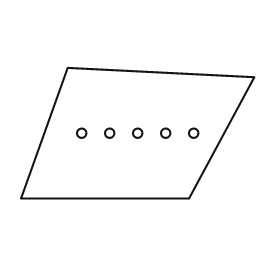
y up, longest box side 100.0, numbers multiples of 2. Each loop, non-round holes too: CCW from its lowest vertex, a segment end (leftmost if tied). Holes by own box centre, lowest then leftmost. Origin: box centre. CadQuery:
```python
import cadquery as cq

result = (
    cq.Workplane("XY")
    .moveTo(-50.0, -28.0)
    .lineTo(22.0, -28.0)
    .lineTo(50.0, 24.0)
    .lineTo(-30.0, 28.0)
    .close()
    .moveTo(-24.0, 0.0)
    .circle(2.0)
    .moveTo(-12.0, 0.0)
    .circle(2.0)
    .moveTo(0.0, 0.0)
    .circle(2.0)
    .moveTo(12.0, 0.0)
    .circle(2.0)
    .moveTo(24.0, 0.0)
    .circle(2.0)
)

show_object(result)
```